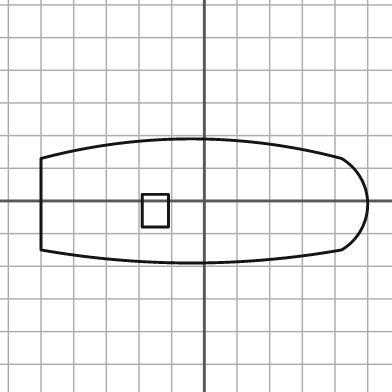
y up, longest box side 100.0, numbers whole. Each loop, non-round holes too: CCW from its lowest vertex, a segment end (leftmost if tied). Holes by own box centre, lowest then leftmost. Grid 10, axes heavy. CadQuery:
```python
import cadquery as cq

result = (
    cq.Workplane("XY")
    .moveTo(-50.0, -15.0)
    .threePointArc((-4.0, -19.0), (42.0, -15.0))
    .threePointArc((50.0, -1.0), (42.0, 13.0))
    .threePointArc((-4.0, 19.0), (-50.0, 13.0))
    .close()
    .moveTo(-19.0, -8.0)
    .lineTo(-11.0, -8.0)
    .lineTo(-11.0, 2.0)
    .lineTo(-19.0, 2.0)
    .close()
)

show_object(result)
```